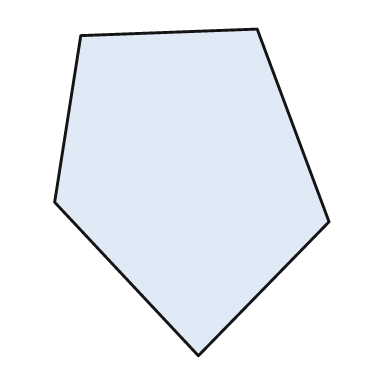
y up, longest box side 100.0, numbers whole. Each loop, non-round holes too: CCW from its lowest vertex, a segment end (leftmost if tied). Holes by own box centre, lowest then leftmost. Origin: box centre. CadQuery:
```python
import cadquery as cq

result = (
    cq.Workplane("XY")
    .moveTo(2.0, -50.0)
    .lineTo(42.0, -9.0)
    .lineTo(20.0, 50.0)
    .lineTo(-34.0, 48.0)
    .lineTo(-42.0, -3.0)
    .close()
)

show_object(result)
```